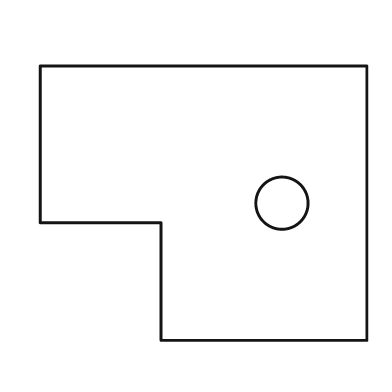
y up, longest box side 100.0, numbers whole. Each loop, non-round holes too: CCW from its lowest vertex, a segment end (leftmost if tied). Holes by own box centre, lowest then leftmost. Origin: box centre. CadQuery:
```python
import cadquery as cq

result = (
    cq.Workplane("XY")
    .moveTo(-13.0, -42.0)
    .lineTo(50.0, -42.0)
    .lineTo(50.0, 42.0)
    .lineTo(-50.0, 42.0)
    .lineTo(-50.0, -6.0)
    .lineTo(-13.0, -6.0)
    .close()
    .moveTo(24.0, 0.0)
    .circle(8.0)
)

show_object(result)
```